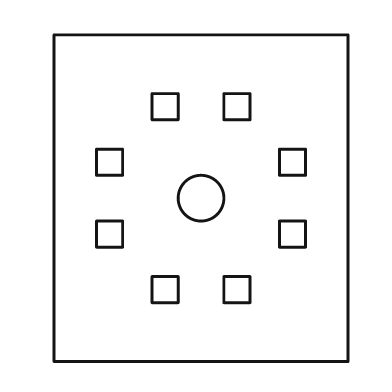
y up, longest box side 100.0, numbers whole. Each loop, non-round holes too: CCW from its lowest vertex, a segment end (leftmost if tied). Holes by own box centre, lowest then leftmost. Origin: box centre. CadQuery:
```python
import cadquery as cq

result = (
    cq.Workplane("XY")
    .moveTo(-45.0, -50.0)
    .lineTo(45.0, -50.0)
    .lineTo(45.0, 50.0)
    .lineTo(-45.0, 50.0)
    .close()
    .moveTo(-15.0, -32.0)
    .lineTo(-7.0, -32.0)
    .lineTo(-7.0, -24.0)
    .lineTo(-15.0, -24.0)
    .close()
    .moveTo(7.0, -32.0)
    .lineTo(15.0, -32.0)
    .lineTo(15.0, -24.0)
    .lineTo(7.0, -24.0)
    .close()
    .moveTo(-32.0, -15.0)
    .lineTo(-24.0, -15.0)
    .lineTo(-24.0, -7.0)
    .lineTo(-32.0, -7.0)
    .close()
    .moveTo(24.0, -15.0)
    .lineTo(32.0, -15.0)
    .lineTo(32.0, -7.0)
    .lineTo(24.0, -7.0)
    .close()
    .moveTo(0.0, 0.0)
    .circle(7.0)
    .moveTo(-32.0, 7.0)
    .lineTo(-24.0, 7.0)
    .lineTo(-24.0, 15.0)
    .lineTo(-32.0, 15.0)
    .close()
    .moveTo(24.0, 7.0)
    .lineTo(32.0, 7.0)
    .lineTo(32.0, 15.0)
    .lineTo(24.0, 15.0)
    .close()
    .moveTo(-15.0, 24.0)
    .lineTo(-7.0, 24.0)
    .lineTo(-7.0, 32.0)
    .lineTo(-15.0, 32.0)
    .close()
    .moveTo(7.0, 24.0)
    .lineTo(15.0, 24.0)
    .lineTo(15.0, 32.0)
    .lineTo(7.0, 32.0)
    .close()
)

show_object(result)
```